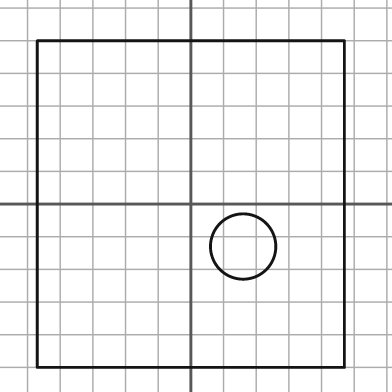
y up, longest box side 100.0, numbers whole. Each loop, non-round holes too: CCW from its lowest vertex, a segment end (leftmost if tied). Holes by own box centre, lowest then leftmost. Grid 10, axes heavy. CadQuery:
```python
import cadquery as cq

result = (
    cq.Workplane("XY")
    .moveTo(-47.0, -50.0)
    .lineTo(47.0, -50.0)
    .lineTo(47.0, 50.0)
    .lineTo(-47.0, 50.0)
    .close()
    .moveTo(16.0, -13.0)
    .circle(10.0)
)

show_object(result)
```